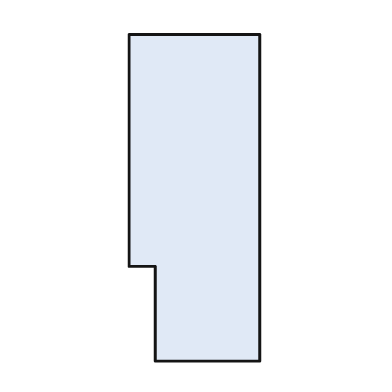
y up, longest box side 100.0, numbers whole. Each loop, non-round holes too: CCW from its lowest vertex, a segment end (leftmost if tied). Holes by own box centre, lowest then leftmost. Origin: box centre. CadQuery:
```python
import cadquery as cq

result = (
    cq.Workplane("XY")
    .moveTo(-12.0, -50.0)
    .lineTo(20.0, -50.0)
    .lineTo(20.0, 50.0)
    .lineTo(-20.0, 50.0)
    .lineTo(-20.0, -21.0)
    .lineTo(-12.0, -21.0)
    .close()
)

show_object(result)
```